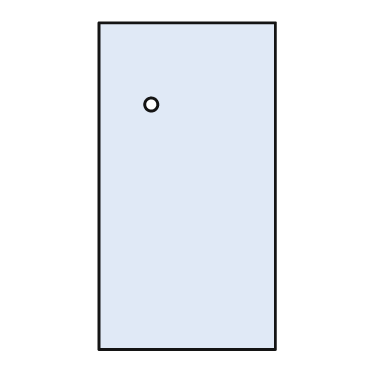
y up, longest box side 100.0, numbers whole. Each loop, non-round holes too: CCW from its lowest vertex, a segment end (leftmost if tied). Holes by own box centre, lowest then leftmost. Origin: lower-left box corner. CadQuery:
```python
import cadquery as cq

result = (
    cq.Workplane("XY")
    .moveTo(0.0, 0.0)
    .lineTo(54.0, 0.0)
    .lineTo(54.0, 100.0)
    .lineTo(0.0, 100.0)
    .close()
    .moveTo(16.0, 75.0)
    .circle(2.0)
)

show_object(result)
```